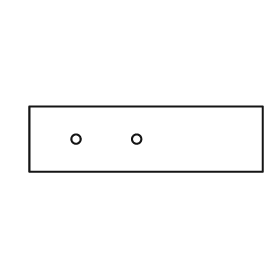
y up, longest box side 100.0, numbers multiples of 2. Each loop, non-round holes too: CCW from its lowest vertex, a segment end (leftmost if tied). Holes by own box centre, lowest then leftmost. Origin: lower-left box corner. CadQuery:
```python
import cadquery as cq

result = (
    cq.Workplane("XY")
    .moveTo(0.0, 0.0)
    .lineTo(100.0, 0.0)
    .lineTo(100.0, 28.0)
    .lineTo(0.0, 28.0)
    .close()
    .moveTo(20.0, 14.0)
    .circle(2.0)
    .moveTo(46.0, 14.0)
    .circle(2.0)
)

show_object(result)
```